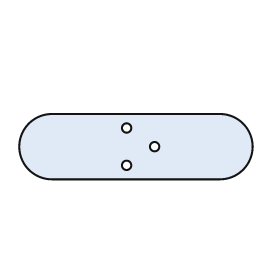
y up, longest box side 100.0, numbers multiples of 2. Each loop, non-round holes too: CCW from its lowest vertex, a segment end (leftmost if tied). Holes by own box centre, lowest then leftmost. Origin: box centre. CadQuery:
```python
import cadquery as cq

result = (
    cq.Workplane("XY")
    .moveTo(-36.0, -14.0)
    .lineTo(36.0, -14.0)
    .threePointArc((50.0, 0.0), (36.0, 14.0))
    .lineTo(-36.0, 14.0)
    .threePointArc((-50.0, 0.0), (-36.0, -14.0))
    .close()
    .moveTo(-4.0, -8.0)
    .circle(2.0)
    .moveTo(8.0, 0.0)
    .circle(2.0)
    .moveTo(-4.0, 8.0)
    .circle(2.0)
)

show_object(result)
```